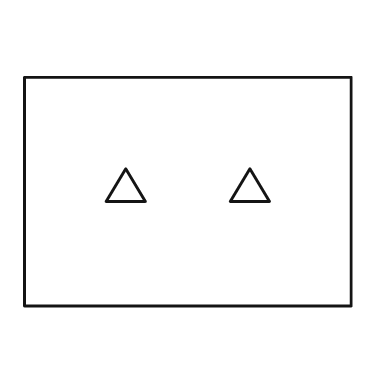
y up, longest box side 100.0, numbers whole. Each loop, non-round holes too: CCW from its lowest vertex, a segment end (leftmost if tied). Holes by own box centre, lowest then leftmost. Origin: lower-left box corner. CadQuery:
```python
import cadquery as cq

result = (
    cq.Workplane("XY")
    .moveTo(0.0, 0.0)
    .lineTo(100.0, 0.0)
    .lineTo(100.0, 70.0)
    .lineTo(0.0, 70.0)
    .close()
    .moveTo(25.0, 32.0)
    .lineTo(37.0, 32.0)
    .lineTo(31.0, 42.0)
    .close()
    .moveTo(63.0, 32.0)
    .lineTo(75.0, 32.0)
    .lineTo(69.0, 42.0)
    .close()
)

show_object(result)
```